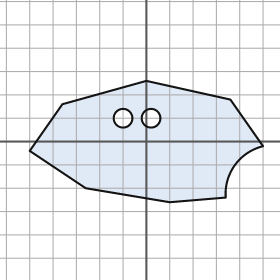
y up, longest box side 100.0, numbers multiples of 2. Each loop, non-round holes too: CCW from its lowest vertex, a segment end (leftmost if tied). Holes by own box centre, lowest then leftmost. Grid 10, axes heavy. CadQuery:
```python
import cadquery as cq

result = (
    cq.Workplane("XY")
    .moveTo(10.0, -26.0)
    .lineTo(34.0, -24.0)
    .threePointArc((38.0, -10.0), (50.0, -2.0))
    .lineTo(36.0, 18.0)
    .lineTo(0.0, 26.0)
    .lineTo(-36.0, 16.0)
    .lineTo(-50.0, -4.0)
    .lineTo(-26.0, -20.0)
    .close()
    .moveTo(-10.0, 10.0)
    .circle(4.0)
    .moveTo(2.0, 10.0)
    .circle(4.0)
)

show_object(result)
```